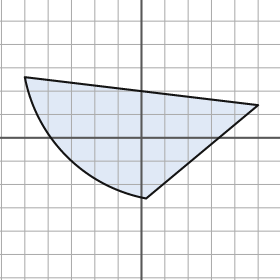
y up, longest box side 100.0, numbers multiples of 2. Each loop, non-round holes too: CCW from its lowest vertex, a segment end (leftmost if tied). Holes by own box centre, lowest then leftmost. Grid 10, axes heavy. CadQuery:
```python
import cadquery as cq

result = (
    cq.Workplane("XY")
    .moveTo(2.0, -26.0)
    .lineTo(50.0, 14.0)
    .lineTo(-50.0, 26.0)
    .threePointArc((-32.0, -8.0), (2.0, -26.0))
    .close()
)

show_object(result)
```